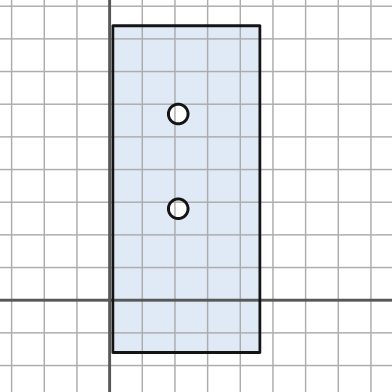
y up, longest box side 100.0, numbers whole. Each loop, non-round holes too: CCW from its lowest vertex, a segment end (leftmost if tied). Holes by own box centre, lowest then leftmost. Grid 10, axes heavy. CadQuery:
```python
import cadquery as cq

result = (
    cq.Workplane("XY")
    .moveTo(1.0, -16.0)
    .lineTo(46.0, -16.0)
    .lineTo(46.0, 84.0)
    .lineTo(1.0, 84.0)
    .close()
    .moveTo(21.0, 28.0)
    .circle(3.0)
    .moveTo(21.0, 57.0)
    .circle(3.0)
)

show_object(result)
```